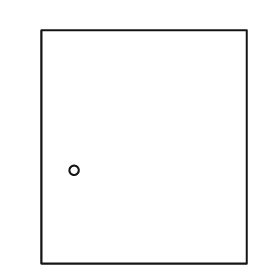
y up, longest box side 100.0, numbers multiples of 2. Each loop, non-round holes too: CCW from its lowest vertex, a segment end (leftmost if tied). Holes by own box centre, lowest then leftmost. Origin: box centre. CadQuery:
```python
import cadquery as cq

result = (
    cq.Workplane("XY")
    .moveTo(-44.0, -50.0)
    .lineTo(44.0, -50.0)
    .lineTo(44.0, 50.0)
    .lineTo(-44.0, 50.0)
    .close()
    .moveTo(-30.0, -10.0)
    .circle(2.0)
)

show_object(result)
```